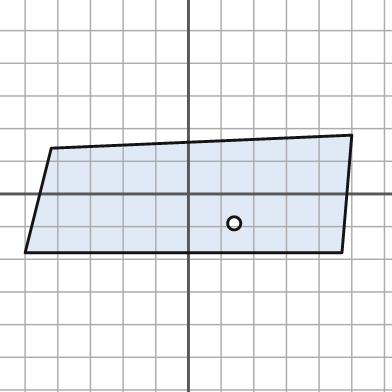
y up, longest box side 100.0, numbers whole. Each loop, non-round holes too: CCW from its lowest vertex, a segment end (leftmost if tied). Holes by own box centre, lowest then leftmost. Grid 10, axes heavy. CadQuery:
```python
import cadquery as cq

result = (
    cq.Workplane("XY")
    .moveTo(-50.0, -18.0)
    .lineTo(47.0, -18.0)
    .lineTo(50.0, 18.0)
    .lineTo(-42.0, 14.0)
    .close()
    .moveTo(14.0, -9.0)
    .circle(2.0)
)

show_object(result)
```